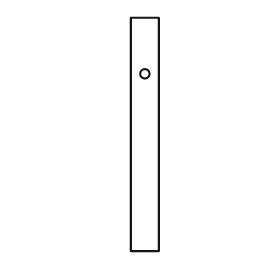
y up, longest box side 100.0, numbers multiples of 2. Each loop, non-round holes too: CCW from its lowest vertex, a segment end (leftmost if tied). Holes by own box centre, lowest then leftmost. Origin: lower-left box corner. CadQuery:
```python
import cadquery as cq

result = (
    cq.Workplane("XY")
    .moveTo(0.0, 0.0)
    .lineTo(12.0, 0.0)
    .lineTo(12.0, 100.0)
    .lineTo(0.0, 100.0)
    .close()
    .moveTo(6.0, 76.0)
    .circle(2.0)
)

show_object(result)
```